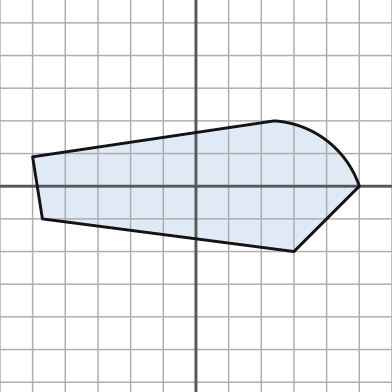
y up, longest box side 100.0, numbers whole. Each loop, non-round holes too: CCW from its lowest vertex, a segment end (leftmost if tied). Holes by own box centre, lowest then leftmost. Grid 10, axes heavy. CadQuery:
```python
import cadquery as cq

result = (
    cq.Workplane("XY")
    .moveTo(30.0, -20.0)
    .lineTo(50.0, 0.0)
    .threePointArc((40.0, 14.0), (24.0, 20.0))
    .lineTo(-50.0, 9.0)
    .lineTo(-47.0, -10.0)
    .close()
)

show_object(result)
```